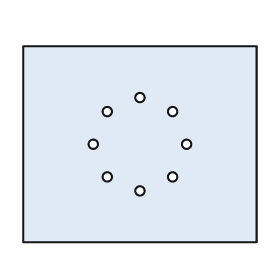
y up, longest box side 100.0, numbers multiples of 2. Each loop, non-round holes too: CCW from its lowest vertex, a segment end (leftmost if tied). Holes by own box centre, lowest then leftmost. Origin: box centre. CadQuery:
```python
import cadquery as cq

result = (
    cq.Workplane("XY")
    .moveTo(-50.0, -42.0)
    .lineTo(50.0, -42.0)
    .lineTo(50.0, 42.0)
    .lineTo(-50.0, 42.0)
    .close()
    .moveTo(0.0, -20.0)
    .circle(2.0)
    .moveTo(-14.0, -14.0)
    .circle(2.0)
    .moveTo(14.0, -14.0)
    .circle(2.0)
    .moveTo(-20.0, 0.0)
    .circle(2.0)
    .moveTo(20.0, 0.0)
    .circle(2.0)
    .moveTo(-14.0, 14.0)
    .circle(2.0)
    .moveTo(14.0, 14.0)
    .circle(2.0)
    .moveTo(0.0, 20.0)
    .circle(2.0)
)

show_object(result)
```